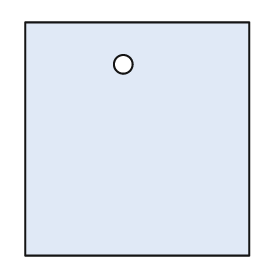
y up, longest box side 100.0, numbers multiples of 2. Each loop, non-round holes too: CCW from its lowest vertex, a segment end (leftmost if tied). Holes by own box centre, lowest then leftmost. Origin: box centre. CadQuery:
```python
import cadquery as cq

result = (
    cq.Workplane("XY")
    .moveTo(-48.0, -50.0)
    .lineTo(48.0, -50.0)
    .lineTo(48.0, 50.0)
    .lineTo(-48.0, 50.0)
    .close()
    .moveTo(-6.0, 32.0)
    .circle(4.0)
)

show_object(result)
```